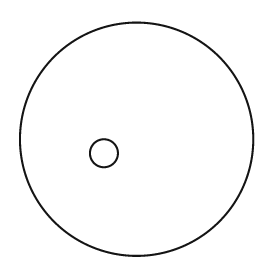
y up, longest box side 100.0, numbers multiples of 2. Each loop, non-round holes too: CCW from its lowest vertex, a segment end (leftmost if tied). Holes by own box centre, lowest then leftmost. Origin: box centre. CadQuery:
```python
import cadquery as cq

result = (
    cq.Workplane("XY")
    .moveTo(0.0, 0.0)
    .circle(50.0)
    .moveTo(-14.0, -6.0)
    .circle(6.0)
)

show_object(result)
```